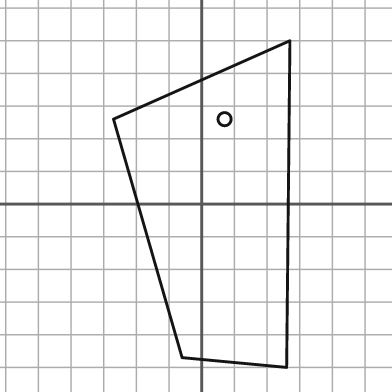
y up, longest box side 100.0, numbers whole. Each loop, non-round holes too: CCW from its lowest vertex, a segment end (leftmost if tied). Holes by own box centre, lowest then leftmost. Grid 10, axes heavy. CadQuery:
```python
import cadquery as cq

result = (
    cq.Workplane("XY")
    .moveTo(26.0, -50.0)
    .lineTo(27.0, 50.0)
    .lineTo(-27.0, 26.0)
    .lineTo(-6.0, -47.0)
    .close()
    .moveTo(7.0, 26.0)
    .circle(2.0)
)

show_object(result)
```